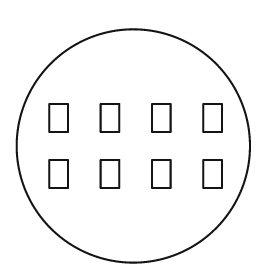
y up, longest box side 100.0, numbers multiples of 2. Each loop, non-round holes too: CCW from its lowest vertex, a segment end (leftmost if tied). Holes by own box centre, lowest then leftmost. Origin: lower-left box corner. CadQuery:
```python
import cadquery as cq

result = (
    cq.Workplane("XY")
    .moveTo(50.0, 50.0)
    .circle(50.0)
    .moveTo(14.0, 32.0)
    .lineTo(22.0, 32.0)
    .lineTo(22.0, 44.0)
    .lineTo(14.0, 44.0)
    .close()
    .moveTo(36.0, 32.0)
    .lineTo(44.0, 32.0)
    .lineTo(44.0, 44.0)
    .lineTo(36.0, 44.0)
    .close()
    .moveTo(58.0, 32.0)
    .lineTo(66.0, 32.0)
    .lineTo(66.0, 44.0)
    .lineTo(58.0, 44.0)
    .close()
    .moveTo(80.0, 32.0)
    .lineTo(88.0, 32.0)
    .lineTo(88.0, 44.0)
    .lineTo(80.0, 44.0)
    .close()
    .moveTo(14.0, 56.0)
    .lineTo(22.0, 56.0)
    .lineTo(22.0, 68.0)
    .lineTo(14.0, 68.0)
    .close()
    .moveTo(36.0, 56.0)
    .lineTo(44.0, 56.0)
    .lineTo(44.0, 68.0)
    .lineTo(36.0, 68.0)
    .close()
    .moveTo(58.0, 56.0)
    .lineTo(66.0, 56.0)
    .lineTo(66.0, 68.0)
    .lineTo(58.0, 68.0)
    .close()
    .moveTo(80.0, 56.0)
    .lineTo(88.0, 56.0)
    .lineTo(88.0, 68.0)
    .lineTo(80.0, 68.0)
    .close()
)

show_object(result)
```